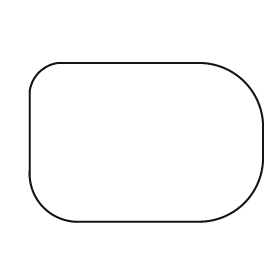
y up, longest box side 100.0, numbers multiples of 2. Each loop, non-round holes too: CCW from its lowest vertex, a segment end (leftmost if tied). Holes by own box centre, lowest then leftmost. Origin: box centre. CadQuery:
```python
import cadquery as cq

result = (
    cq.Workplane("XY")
    .moveTo(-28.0, -34.0)
    .lineTo(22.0, -34.0)
    .threePointArc((42.0, -26.0), (50.0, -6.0))
    .lineTo(50.0, 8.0)
    .threePointArc((42.0, 26.0), (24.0, 34.0))
    .lineTo(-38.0, 34.0)
    .threePointArc((-46.0, 30.0), (-50.0, 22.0))
    .lineTo(-50.0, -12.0)
    .threePointArc((-44.0, -28.0), (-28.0, -34.0))
    .close()
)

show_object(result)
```